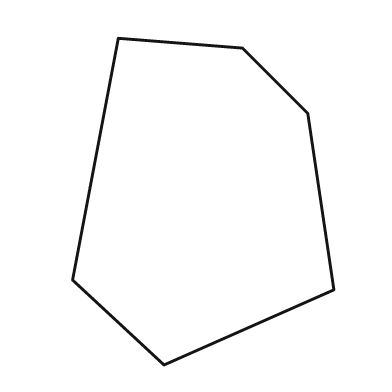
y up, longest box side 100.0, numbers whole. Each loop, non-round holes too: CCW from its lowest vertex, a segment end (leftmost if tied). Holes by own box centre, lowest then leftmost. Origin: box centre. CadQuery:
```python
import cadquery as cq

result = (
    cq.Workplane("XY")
    .moveTo(-12.0, -50.0)
    .lineTo(40.0, -27.0)
    .lineTo(32.0, 27.0)
    .lineTo(12.0, 47.0)
    .lineTo(-26.0, 50.0)
    .lineTo(-40.0, -24.0)
    .close()
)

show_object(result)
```